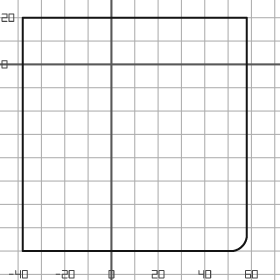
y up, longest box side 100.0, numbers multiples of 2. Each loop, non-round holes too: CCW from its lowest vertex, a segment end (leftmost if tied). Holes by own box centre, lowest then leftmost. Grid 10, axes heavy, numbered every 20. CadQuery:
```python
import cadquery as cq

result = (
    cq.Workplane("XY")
    .moveTo(-38.0, -80.0)
    .lineTo(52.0, -80.0)
    .threePointArc((56.0, -78.0), (58.0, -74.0))
    .lineTo(58.0, 20.0)
    .lineTo(-38.0, 20.0)
    .close()
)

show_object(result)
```